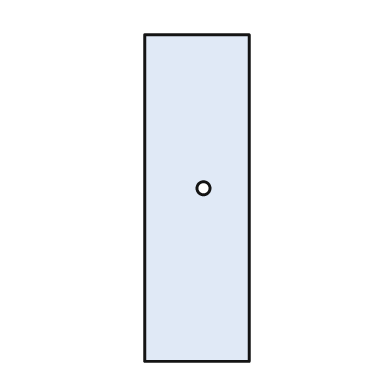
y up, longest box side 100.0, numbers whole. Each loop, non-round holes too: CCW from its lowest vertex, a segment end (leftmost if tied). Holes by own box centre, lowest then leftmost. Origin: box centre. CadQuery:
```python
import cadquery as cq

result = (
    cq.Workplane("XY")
    .moveTo(-16.0, -50.0)
    .lineTo(16.0, -50.0)
    .lineTo(16.0, 50.0)
    .lineTo(-16.0, 50.0)
    .close()
    .moveTo(2.0, 3.0)
    .circle(2.0)
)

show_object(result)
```